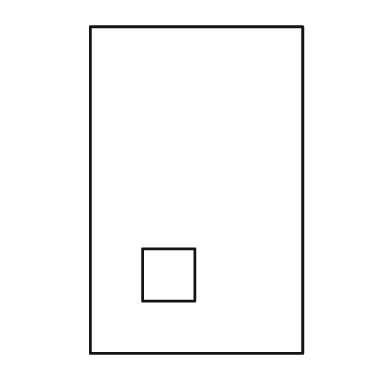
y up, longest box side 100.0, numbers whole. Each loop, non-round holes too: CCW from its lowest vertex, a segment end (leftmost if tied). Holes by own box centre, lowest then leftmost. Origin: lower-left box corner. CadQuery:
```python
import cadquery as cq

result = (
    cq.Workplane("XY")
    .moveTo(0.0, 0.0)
    .lineTo(65.0, 0.0)
    .lineTo(65.0, 100.0)
    .lineTo(0.0, 100.0)
    .close()
    .moveTo(16.0, 16.0)
    .lineTo(32.0, 16.0)
    .lineTo(32.0, 32.0)
    .lineTo(16.0, 32.0)
    .close()
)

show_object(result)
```